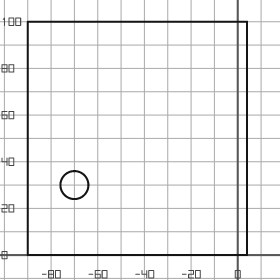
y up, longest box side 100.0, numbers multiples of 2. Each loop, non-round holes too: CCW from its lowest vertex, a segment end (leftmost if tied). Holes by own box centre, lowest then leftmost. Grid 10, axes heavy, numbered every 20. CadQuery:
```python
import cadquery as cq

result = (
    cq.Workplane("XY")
    .moveTo(-90.0, 0.0)
    .lineTo(4.0, 0.0)
    .lineTo(4.0, 100.0)
    .lineTo(-90.0, 100.0)
    .close()
    .moveTo(-70.0, 30.0)
    .circle(6.0)
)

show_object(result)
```